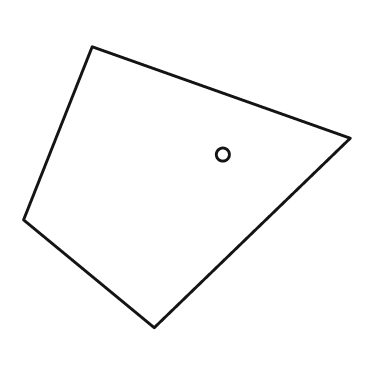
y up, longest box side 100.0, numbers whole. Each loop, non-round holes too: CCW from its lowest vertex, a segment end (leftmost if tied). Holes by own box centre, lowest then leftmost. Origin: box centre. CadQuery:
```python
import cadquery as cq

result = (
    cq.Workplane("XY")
    .moveTo(-10.0, -43.0)
    .lineTo(50.0, 15.0)
    .lineTo(-29.0, 43.0)
    .lineTo(-50.0, -10.0)
    .close()
    .moveTo(11.0, 10.0)
    .circle(2.0)
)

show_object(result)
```